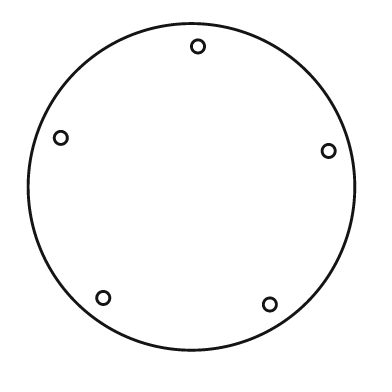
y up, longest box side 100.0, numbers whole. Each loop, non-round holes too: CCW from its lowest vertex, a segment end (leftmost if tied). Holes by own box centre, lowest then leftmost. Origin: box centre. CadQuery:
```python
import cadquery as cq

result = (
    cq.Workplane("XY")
    .moveTo(0.0, 0.0)
    .circle(50.0)
    .moveTo(24.0, -36.0)
    .circle(2.0)
    .moveTo(-27.0, -34.0)
    .circle(2.0)
    .moveTo(42.0, 11.0)
    .circle(2.0)
    .moveTo(-40.0, 15.0)
    .circle(2.0)
    .moveTo(2.0, 43.0)
    .circle(2.0)
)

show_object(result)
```